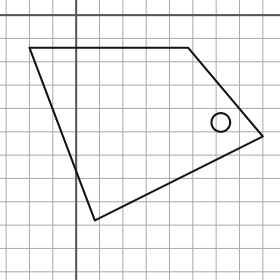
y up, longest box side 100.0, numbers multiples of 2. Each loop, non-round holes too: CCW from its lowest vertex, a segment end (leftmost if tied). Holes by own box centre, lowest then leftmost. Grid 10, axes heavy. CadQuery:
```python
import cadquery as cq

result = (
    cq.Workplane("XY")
    .moveTo(8.0, -88.0)
    .lineTo(80.0, -52.0)
    .lineTo(48.0, -14.0)
    .lineTo(-20.0, -14.0)
    .close()
    .moveTo(62.0, -46.0)
    .circle(4.0)
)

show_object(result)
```